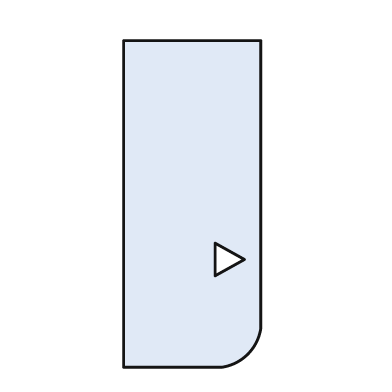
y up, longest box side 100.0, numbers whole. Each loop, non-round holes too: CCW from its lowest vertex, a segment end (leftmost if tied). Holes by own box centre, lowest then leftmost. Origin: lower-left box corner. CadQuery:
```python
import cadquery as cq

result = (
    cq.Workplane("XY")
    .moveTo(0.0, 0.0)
    .lineTo(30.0, 0.0)
    .threePointArc((38.0, 4.0), (42.0, 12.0))
    .lineTo(42.0, 100.0)
    .lineTo(0.0, 100.0)
    .close()
    .moveTo(28.0, 28.0)
    .lineTo(37.0, 33.0)
    .lineTo(28.0, 38.0)
    .close()
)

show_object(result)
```